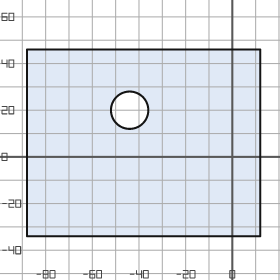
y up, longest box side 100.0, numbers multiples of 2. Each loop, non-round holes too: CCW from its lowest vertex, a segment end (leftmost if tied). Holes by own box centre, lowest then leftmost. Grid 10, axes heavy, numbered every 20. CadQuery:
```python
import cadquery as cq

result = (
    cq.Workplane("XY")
    .moveTo(-88.0, -34.0)
    .lineTo(12.0, -34.0)
    .lineTo(12.0, 46.0)
    .lineTo(-88.0, 46.0)
    .close()
    .moveTo(-44.0, 20.0)
    .circle(8.0)
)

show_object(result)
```